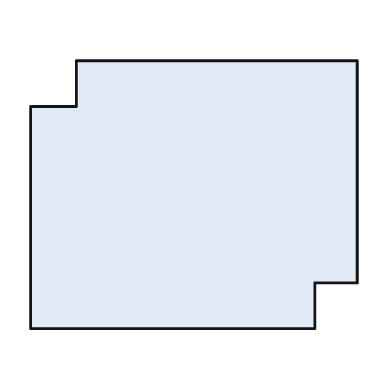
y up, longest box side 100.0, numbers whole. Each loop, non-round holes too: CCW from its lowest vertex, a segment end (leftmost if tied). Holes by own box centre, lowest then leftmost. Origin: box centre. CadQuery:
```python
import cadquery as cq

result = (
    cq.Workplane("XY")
    .moveTo(-50.0, -41.0)
    .lineTo(37.0, -41.0)
    .lineTo(37.0, -27.0)
    .lineTo(50.0, -27.0)
    .lineTo(50.0, 41.0)
    .lineTo(-36.0, 41.0)
    .lineTo(-36.0, 27.0)
    .lineTo(-50.0, 27.0)
    .close()
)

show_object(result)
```